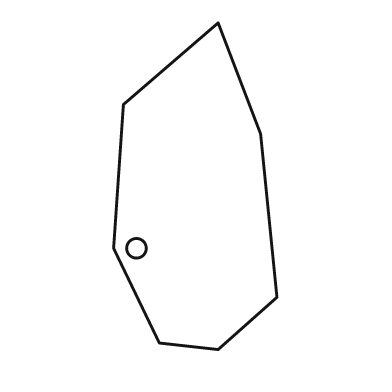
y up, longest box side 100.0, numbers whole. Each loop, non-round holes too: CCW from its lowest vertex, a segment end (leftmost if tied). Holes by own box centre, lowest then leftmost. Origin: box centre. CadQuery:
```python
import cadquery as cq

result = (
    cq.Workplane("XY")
    .moveTo(7.0, -50.0)
    .lineTo(25.0, -34.0)
    .lineTo(20.0, 16.0)
    .lineTo(7.0, 50.0)
    .lineTo(-22.0, 25.0)
    .lineTo(-25.0, -19.0)
    .lineTo(-11.0, -48.0)
    .close()
    .moveTo(-18.0, -19.0)
    .circle(3.0)
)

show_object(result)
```